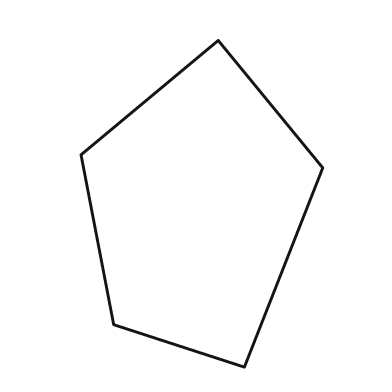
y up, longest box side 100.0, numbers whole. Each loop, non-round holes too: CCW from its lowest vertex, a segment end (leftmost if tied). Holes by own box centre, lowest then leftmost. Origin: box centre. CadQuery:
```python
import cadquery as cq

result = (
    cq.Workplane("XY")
    .moveTo(13.0, -50.0)
    .lineTo(37.0, 11.0)
    .lineTo(5.0, 50.0)
    .lineTo(-37.0, 15.0)
    .lineTo(-27.0, -37.0)
    .close()
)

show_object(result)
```